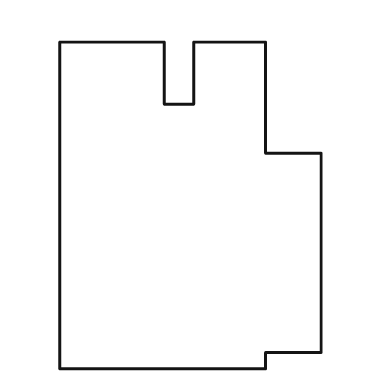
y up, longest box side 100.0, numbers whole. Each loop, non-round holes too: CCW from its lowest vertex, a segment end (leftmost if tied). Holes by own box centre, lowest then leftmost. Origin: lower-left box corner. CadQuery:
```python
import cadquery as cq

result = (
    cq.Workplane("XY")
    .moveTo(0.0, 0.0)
    .lineTo(63.0, 0.0)
    .lineTo(63.0, 5.0)
    .lineTo(80.0, 5.0)
    .lineTo(80.0, 66.0)
    .lineTo(63.0, 66.0)
    .lineTo(63.0, 100.0)
    .lineTo(41.0, 100.0)
    .lineTo(41.0, 81.0)
    .lineTo(32.0, 81.0)
    .lineTo(32.0, 100.0)
    .lineTo(0.0, 100.0)
    .close()
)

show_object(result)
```